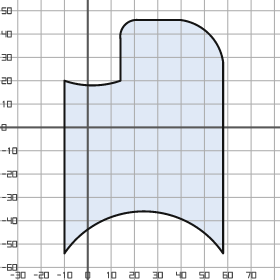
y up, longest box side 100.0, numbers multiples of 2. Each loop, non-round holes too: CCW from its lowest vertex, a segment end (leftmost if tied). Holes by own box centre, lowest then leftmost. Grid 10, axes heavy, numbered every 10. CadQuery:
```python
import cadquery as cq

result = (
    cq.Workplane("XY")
    .moveTo(-10.0, -54.0)
    .threePointArc((24.0, -36.0), (58.0, -54.0))
    .lineTo(58.0, 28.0)
    .threePointArc((52.0, 40.0), (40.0, 46.0))
    .lineTo(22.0, 46.0)
    .threePointArc((16.0, 44.0), (14.0, 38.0))
    .lineTo(14.0, 20.0)
    .threePointArc((2.0, 18.0), (-10.0, 20.0))
    .close()
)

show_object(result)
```